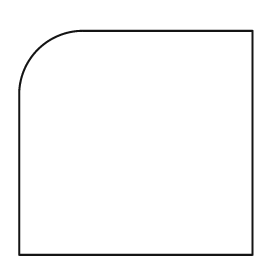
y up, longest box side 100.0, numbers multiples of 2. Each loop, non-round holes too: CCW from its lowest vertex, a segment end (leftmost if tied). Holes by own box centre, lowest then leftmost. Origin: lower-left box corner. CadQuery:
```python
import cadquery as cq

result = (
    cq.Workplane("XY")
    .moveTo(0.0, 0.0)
    .lineTo(100.0, 0.0)
    .lineTo(100.0, 96.0)
    .lineTo(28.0, 96.0)
    .threePointArc((8.0, 88.0), (0.0, 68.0))
    .close()
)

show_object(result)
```